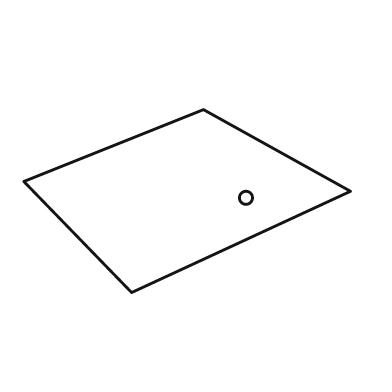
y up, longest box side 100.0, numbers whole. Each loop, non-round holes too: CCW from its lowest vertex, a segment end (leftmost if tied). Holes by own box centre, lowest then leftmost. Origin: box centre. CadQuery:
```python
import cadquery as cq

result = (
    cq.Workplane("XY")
    .moveTo(-17.0, -28.0)
    .lineTo(50.0, 3.0)
    .lineTo(5.0, 28.0)
    .lineTo(-50.0, 6.0)
    .close()
    .moveTo(18.0, 1.0)
    .circle(2.0)
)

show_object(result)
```